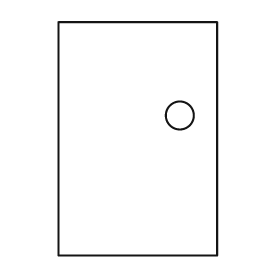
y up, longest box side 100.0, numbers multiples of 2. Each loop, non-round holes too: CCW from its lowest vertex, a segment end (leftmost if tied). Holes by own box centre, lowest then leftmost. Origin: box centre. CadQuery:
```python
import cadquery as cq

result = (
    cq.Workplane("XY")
    .moveTo(-34.0, -50.0)
    .lineTo(34.0, -50.0)
    .lineTo(34.0, 50.0)
    .lineTo(-34.0, 50.0)
    .close()
    .moveTo(18.0, 10.0)
    .circle(6.0)
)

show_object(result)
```